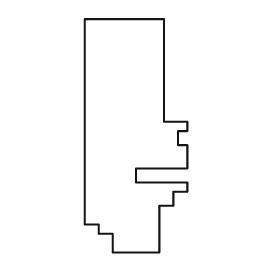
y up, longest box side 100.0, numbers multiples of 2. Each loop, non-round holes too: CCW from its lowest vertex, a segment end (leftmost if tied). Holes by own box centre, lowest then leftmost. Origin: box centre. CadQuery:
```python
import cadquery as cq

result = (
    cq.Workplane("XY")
    .moveTo(-10.0, -50.0)
    .lineTo(10.0, -50.0)
    .lineTo(10.0, -30.0)
    .lineTo(16.0, -30.0)
    .lineTo(16.0, -24.0)
    .lineTo(22.0, -24.0)
    .lineTo(22.0, -20.0)
    .lineTo(0.0, -20.0)
    .lineTo(0.0, -14.0)
    .lineTo(22.0, -14.0)
    .lineTo(22.0, -4.0)
    .lineTo(18.0, -4.0)
    .lineTo(18.0, 2.0)
    .lineTo(22.0, 2.0)
    .lineTo(22.0, 6.0)
    .lineTo(12.0, 6.0)
    .lineTo(12.0, 50.0)
    .lineTo(-22.0, 50.0)
    .lineTo(-22.0, -38.0)
    .lineTo(-16.0, -38.0)
    .lineTo(-16.0, -42.0)
    .lineTo(-10.0, -42.0)
    .close()
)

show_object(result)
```